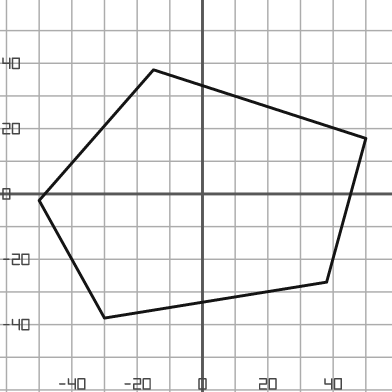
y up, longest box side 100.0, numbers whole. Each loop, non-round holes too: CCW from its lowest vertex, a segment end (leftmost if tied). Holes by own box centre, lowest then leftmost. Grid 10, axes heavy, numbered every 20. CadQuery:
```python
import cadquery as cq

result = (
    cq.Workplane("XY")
    .moveTo(-30.0, -38.0)
    .lineTo(38.0, -27.0)
    .lineTo(50.0, 17.0)
    .lineTo(-15.0, 38.0)
    .lineTo(-50.0, -2.0)
    .close()
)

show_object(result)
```